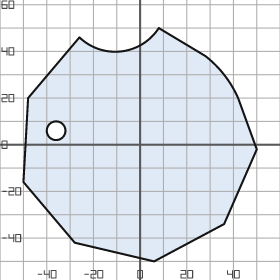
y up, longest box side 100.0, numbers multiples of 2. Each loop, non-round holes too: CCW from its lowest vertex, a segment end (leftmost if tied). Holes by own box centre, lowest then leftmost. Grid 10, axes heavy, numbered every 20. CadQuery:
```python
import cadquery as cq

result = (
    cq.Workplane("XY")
    .moveTo(6.0, -50.0)
    .lineTo(36.0, -34.0)
    .lineTo(50.0, -2.0)
    .lineTo(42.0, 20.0)
    .threePointArc((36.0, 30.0), (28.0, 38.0))
    .lineTo(8.0, 50.0)
    .threePointArc((-8.0, 40.0), (-26.0, 46.0))
    .lineTo(-48.0, 20.0)
    .lineTo(-50.0, -16.0)
    .lineTo(-28.0, -42.0)
    .close()
    .moveTo(-36.0, 6.0)
    .circle(4.0)
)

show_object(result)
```